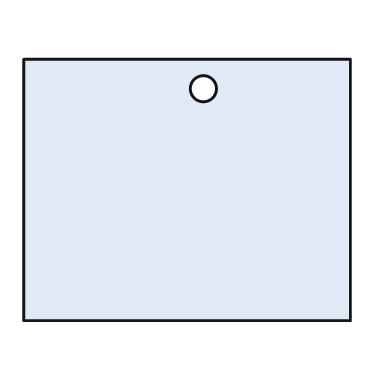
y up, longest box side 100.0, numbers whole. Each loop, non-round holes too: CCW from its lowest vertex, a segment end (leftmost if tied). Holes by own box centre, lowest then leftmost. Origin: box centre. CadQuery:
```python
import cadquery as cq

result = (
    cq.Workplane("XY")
    .moveTo(-50.0, -40.0)
    .lineTo(50.0, -40.0)
    .lineTo(50.0, 40.0)
    .lineTo(-50.0, 40.0)
    .close()
    .moveTo(5.0, 31.0)
    .circle(4.0)
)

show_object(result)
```